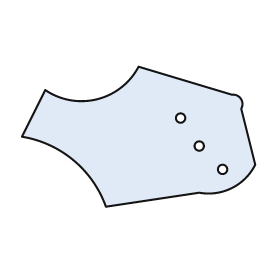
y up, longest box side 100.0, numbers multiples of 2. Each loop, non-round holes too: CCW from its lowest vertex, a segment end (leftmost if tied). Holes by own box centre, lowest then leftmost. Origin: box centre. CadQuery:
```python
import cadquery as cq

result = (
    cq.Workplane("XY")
    .moveTo(-14.0, -30.0)
    .lineTo(26.0, -24.0)
    .threePointArc((40.0, -22.0), (50.0, -12.0))
    .lineTo(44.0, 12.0)
    .threePointArc((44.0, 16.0), (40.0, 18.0))
    .lineTo(0.0, 30.0)
    .threePointArc((-18.0, 16.0), (-40.0, 20.0))
    .lineTo(-50.0, 0.0)
    .threePointArc((-28.0, -10.0), (-14.0, -30.0))
    .close()
    .moveTo(36.0, -14.0)
    .circle(2.0)
    .moveTo(26.0, -4.0)
    .circle(2.0)
    .moveTo(18.0, 8.0)
    .circle(2.0)
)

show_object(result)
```